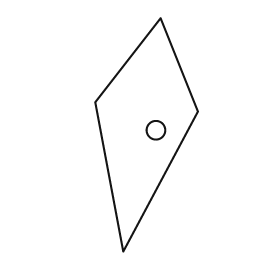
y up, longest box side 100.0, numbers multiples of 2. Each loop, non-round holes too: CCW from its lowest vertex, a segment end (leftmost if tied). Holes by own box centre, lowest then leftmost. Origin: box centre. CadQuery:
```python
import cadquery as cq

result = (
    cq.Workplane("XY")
    .moveTo(-10.0, -50.0)
    .lineTo(22.0, 10.0)
    .lineTo(6.0, 50.0)
    .lineTo(-22.0, 14.0)
    .close()
    .moveTo(4.0, 2.0)
    .circle(4.0)
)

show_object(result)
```